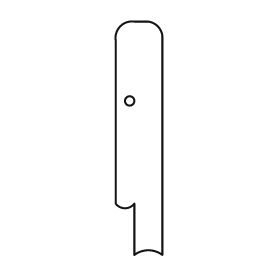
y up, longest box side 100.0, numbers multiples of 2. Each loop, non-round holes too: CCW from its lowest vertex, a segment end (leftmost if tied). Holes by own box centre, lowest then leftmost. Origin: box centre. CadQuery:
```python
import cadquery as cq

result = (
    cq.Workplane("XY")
    .moveTo(-2.0, -50.0)
    .threePointArc((4.0, -48.0), (10.0, -50.0))
    .lineTo(10.0, 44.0)
    .threePointArc((8.0, 48.0), (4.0, 50.0))
    .lineTo(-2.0, 50.0)
    .threePointArc((-8.0, 48.0), (-10.0, 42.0))
    .lineTo(-10.0, -28.0)
    .threePointArc((-6.0, -30.0), (-2.0, -28.0))
    .close()
    .moveTo(-4.0, 16.0)
    .circle(2.0)
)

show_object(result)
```